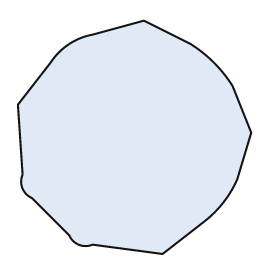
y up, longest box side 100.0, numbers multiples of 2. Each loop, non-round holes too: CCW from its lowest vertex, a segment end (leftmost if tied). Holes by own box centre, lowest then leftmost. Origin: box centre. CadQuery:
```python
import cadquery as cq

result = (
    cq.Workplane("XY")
    .moveTo(12.0, -50.0)
    .lineTo(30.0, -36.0)
    .threePointArc((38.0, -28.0), (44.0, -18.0))
    .lineTo(50.0, 2.0)
    .lineTo(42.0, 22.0)
    .threePointArc((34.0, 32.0), (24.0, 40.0))
    .lineTo(4.0, 50.0)
    .lineTo(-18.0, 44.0)
    .threePointArc((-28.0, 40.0), (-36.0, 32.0))
    .lineTo(-50.0, 14.0)
    .lineTo(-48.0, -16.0)
    .threePointArc((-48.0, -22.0), (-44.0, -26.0))
    .lineTo(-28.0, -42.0)
    .threePointArc((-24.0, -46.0), (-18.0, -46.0))
    .close()
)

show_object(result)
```